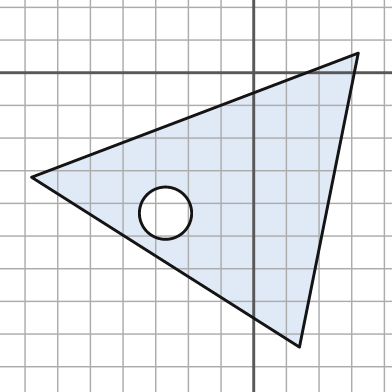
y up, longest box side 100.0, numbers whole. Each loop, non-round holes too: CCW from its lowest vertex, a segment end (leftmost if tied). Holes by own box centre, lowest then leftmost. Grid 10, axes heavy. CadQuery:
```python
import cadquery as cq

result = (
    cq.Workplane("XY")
    .moveTo(14.0, -84.0)
    .lineTo(32.0, 6.0)
    .lineTo(-68.0, -32.0)
    .close()
    .moveTo(-27.0, -43.0)
    .circle(8.0)
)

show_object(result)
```